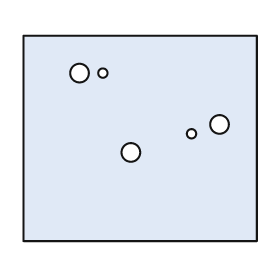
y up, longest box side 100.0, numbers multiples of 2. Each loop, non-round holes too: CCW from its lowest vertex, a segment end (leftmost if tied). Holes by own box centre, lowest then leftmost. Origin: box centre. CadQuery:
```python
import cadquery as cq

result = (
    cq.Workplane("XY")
    .moveTo(-50.0, -44.0)
    .lineTo(50.0, -44.0)
    .lineTo(50.0, 44.0)
    .lineTo(-50.0, 44.0)
    .close()
    .moveTo(-4.0, -6.0)
    .circle(4.0)
    .moveTo(22.0, 2.0)
    .circle(2.0)
    .moveTo(34.0, 6.0)
    .circle(4.0)
    .moveTo(-26.0, 28.0)
    .circle(4.0)
    .moveTo(-16.0, 28.0)
    .circle(2.0)
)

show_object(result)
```